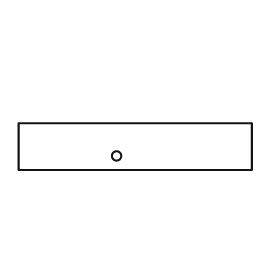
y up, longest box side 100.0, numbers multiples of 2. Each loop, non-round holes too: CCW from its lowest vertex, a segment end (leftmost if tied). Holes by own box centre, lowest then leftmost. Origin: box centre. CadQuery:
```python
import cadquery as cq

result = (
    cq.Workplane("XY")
    .moveTo(-50.0, -10.0)
    .lineTo(50.0, -10.0)
    .lineTo(50.0, 10.0)
    .lineTo(-50.0, 10.0)
    .close()
    .moveTo(-8.0, -4.0)
    .circle(2.0)
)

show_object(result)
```